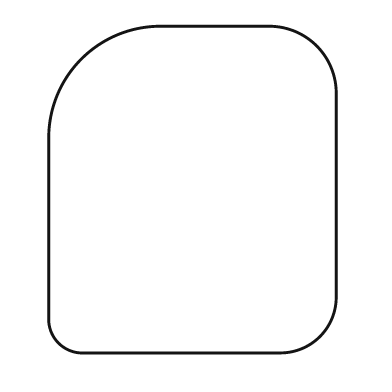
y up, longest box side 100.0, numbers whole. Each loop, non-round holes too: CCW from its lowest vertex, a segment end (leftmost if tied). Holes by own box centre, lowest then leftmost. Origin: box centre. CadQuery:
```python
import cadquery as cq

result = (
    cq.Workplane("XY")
    .moveTo(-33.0, -50.0)
    .lineTo(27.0, -50.0)
    .threePointArc((39.0, -45.0), (44.0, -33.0))
    .lineTo(44.0, 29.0)
    .threePointArc((38.0, 44.0), (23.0, 50.0))
    .lineTo(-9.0, 50.0)
    .threePointArc((-34.0, 40.0), (-44.0, 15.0))
    .lineTo(-44.0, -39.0)
    .threePointArc((-41.0, -47.0), (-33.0, -50.0))
    .close()
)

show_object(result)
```